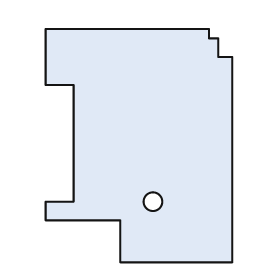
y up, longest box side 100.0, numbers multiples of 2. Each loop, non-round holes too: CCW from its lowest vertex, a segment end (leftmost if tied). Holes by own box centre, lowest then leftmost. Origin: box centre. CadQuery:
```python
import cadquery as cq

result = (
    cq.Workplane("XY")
    .moveTo(-8.0, -50.0)
    .lineTo(40.0, -50.0)
    .lineTo(40.0, 38.0)
    .lineTo(34.0, 38.0)
    .lineTo(34.0, 46.0)
    .lineTo(30.0, 46.0)
    .lineTo(30.0, 50.0)
    .lineTo(-40.0, 50.0)
    .lineTo(-40.0, 26.0)
    .lineTo(-28.0, 26.0)
    .lineTo(-28.0, -24.0)
    .lineTo(-40.0, -24.0)
    .lineTo(-40.0, -32.0)
    .lineTo(-8.0, -32.0)
    .close()
    .moveTo(6.0, -24.0)
    .circle(4.0)
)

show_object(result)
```